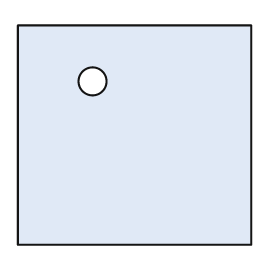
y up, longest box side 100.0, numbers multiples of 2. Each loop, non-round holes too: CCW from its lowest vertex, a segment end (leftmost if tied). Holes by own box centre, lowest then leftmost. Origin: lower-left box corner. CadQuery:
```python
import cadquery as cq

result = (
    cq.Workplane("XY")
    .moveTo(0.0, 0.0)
    .lineTo(100.0, 0.0)
    .lineTo(100.0, 94.0)
    .lineTo(0.0, 94.0)
    .close()
    .moveTo(32.0, 70.0)
    .circle(6.0)
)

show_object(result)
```